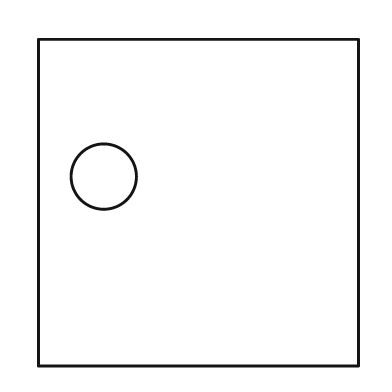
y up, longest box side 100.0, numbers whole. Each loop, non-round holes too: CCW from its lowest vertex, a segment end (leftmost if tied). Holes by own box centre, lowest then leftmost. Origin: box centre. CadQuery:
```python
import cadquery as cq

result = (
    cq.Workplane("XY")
    .moveTo(-49.0, -50.0)
    .lineTo(49.0, -50.0)
    .lineTo(49.0, 50.0)
    .lineTo(-49.0, 50.0)
    .close()
    .moveTo(-29.0, 8.0)
    .circle(10.0)
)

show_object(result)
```